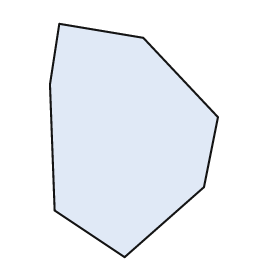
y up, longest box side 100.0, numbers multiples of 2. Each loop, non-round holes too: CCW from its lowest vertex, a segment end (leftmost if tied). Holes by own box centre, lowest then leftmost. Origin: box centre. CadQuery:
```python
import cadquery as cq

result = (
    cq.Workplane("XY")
    .moveTo(-4.0, -50.0)
    .lineTo(30.0, -20.0)
    .lineTo(36.0, 10.0)
    .lineTo(4.0, 44.0)
    .lineTo(-32.0, 50.0)
    .lineTo(-36.0, 24.0)
    .lineTo(-34.0, -30.0)
    .close()
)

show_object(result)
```